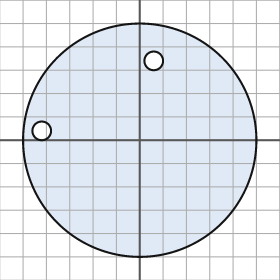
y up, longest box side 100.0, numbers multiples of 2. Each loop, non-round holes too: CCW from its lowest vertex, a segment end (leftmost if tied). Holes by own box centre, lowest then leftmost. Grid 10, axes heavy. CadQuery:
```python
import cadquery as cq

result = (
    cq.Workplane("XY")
    .moveTo(0.0, 0.0)
    .circle(50.0)
    .moveTo(-42.0, 4.0)
    .circle(4.0)
    .moveTo(6.0, 34.0)
    .circle(4.0)
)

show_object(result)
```